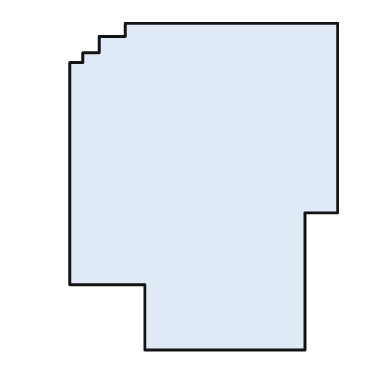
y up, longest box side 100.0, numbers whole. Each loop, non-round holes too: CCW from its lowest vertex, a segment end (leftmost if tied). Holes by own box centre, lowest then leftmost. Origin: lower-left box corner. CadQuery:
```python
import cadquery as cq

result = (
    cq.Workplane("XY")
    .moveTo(23.0, 0.0)
    .lineTo(72.0, 0.0)
    .lineTo(72.0, 42.0)
    .lineTo(82.0, 42.0)
    .lineTo(82.0, 100.0)
    .lineTo(17.0, 100.0)
    .lineTo(17.0, 96.0)
    .lineTo(9.0, 96.0)
    .lineTo(9.0, 91.0)
    .lineTo(4.0, 91.0)
    .lineTo(4.0, 88.0)
    .lineTo(0.0, 88.0)
    .lineTo(0.0, 20.0)
    .lineTo(23.0, 20.0)
    .close()
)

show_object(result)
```